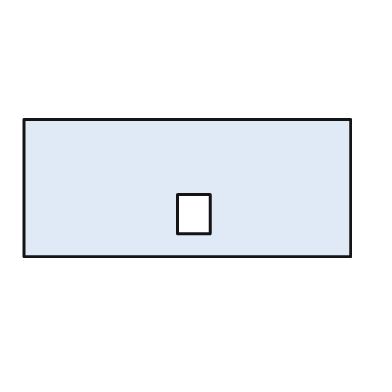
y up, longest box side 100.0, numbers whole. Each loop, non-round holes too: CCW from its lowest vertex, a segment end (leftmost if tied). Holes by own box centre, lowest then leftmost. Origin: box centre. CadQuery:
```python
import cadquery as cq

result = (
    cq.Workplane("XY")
    .moveTo(-50.0, -21.0)
    .lineTo(50.0, -21.0)
    .lineTo(50.0, 21.0)
    .lineTo(-50.0, 21.0)
    .close()
    .moveTo(-3.0, -14.0)
    .lineTo(7.0, -14.0)
    .lineTo(7.0, -2.0)
    .lineTo(-3.0, -2.0)
    .close()
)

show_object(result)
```